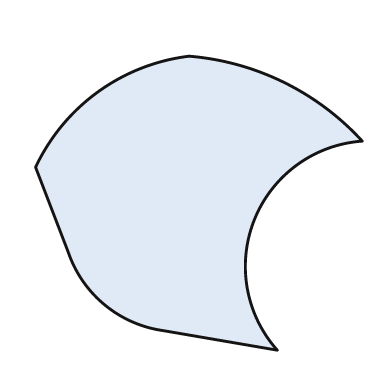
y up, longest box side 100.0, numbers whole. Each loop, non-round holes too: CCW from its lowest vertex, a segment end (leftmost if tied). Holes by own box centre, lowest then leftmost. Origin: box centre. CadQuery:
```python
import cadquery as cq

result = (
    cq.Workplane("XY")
    .moveTo(24.0, -45.0)
    .threePointArc((17.0, -5.0), (50.0, 19.0))
    .threePointArc((26.0, 37.0), (-3.0, 45.0))
    .threePointArc((-31.0, 34.0), (-50.0, 11.0))
    .lineTo(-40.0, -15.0)
    .threePointArc((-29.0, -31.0), (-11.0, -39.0))
    .close()
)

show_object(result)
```